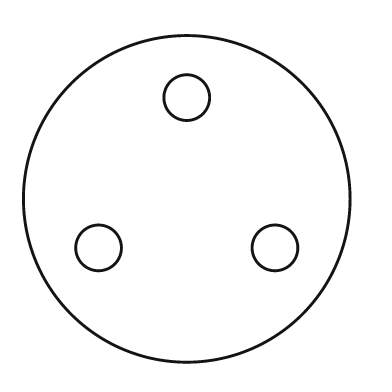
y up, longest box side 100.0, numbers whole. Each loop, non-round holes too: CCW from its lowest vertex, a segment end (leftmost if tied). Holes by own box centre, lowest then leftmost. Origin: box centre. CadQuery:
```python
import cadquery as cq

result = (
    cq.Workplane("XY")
    .moveTo(0.0, 0.0)
    .circle(50.0)
    .moveTo(-27.0, -15.0)
    .circle(7.0)
    .moveTo(27.0, -15.0)
    .circle(7.0)
    .moveTo(0.0, 31.0)
    .circle(7.0)
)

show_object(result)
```